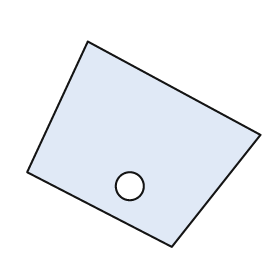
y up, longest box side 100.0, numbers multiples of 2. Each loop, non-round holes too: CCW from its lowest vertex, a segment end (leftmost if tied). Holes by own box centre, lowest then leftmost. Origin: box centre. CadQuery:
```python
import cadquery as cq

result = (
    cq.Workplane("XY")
    .moveTo(12.0, -44.0)
    .lineTo(50.0, 4.0)
    .lineTo(-24.0, 44.0)
    .lineTo(-50.0, -12.0)
    .close()
    .moveTo(-6.0, -18.0)
    .circle(6.0)
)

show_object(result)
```